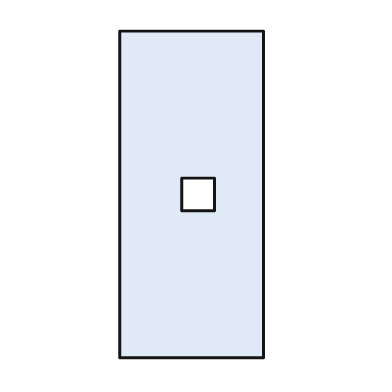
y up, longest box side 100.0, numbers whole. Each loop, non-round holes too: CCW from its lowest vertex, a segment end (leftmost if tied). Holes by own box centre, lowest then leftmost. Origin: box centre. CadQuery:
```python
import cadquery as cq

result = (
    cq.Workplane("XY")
    .moveTo(-22.0, -50.0)
    .lineTo(22.0, -50.0)
    .lineTo(22.0, 50.0)
    .lineTo(-22.0, 50.0)
    .close()
    .moveTo(-3.0, -5.0)
    .lineTo(7.0, -5.0)
    .lineTo(7.0, 5.0)
    .lineTo(-3.0, 5.0)
    .close()
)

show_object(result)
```